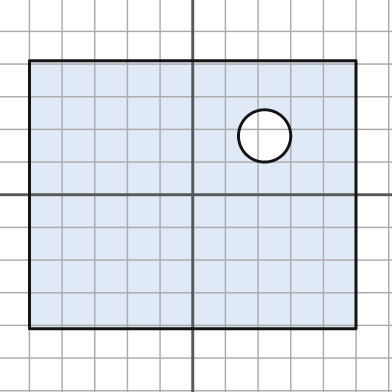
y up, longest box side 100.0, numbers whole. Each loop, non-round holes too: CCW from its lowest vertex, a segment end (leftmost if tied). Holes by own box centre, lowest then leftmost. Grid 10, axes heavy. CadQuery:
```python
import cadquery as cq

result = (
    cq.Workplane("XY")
    .moveTo(-50.0, -41.0)
    .lineTo(50.0, -41.0)
    .lineTo(50.0, 41.0)
    .lineTo(-50.0, 41.0)
    .close()
    .moveTo(22.0, 18.0)
    .circle(8.0)
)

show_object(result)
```